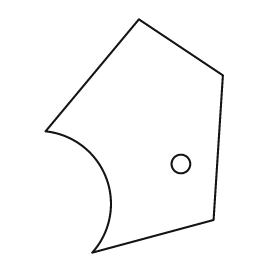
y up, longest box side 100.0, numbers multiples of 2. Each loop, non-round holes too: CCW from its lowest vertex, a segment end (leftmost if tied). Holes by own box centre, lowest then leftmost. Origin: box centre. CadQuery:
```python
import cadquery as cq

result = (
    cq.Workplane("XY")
    .moveTo(-18.0, -50.0)
    .lineTo(34.0, -36.0)
    .lineTo(38.0, 26.0)
    .lineTo(2.0, 50.0)
    .lineTo(-38.0, 2.0)
    .threePointArc((-12.0, -18.0), (-18.0, -50.0))
    .close()
    .moveTo(20.0, -12.0)
    .circle(4.0)
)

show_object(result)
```